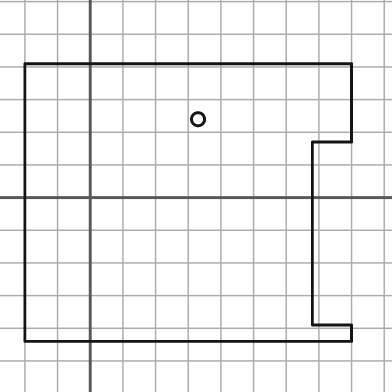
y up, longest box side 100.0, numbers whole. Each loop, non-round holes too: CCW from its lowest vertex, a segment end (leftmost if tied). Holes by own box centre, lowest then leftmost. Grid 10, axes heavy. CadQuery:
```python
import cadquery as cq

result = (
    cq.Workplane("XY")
    .moveTo(-20.0, -44.0)
    .lineTo(80.0, -44.0)
    .lineTo(80.0, -39.0)
    .lineTo(68.0, -39.0)
    .lineTo(68.0, 17.0)
    .lineTo(80.0, 17.0)
    .lineTo(80.0, 41.0)
    .lineTo(-20.0, 41.0)
    .close()
    .moveTo(33.0, 24.0)
    .circle(2.0)
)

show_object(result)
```